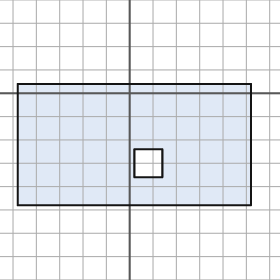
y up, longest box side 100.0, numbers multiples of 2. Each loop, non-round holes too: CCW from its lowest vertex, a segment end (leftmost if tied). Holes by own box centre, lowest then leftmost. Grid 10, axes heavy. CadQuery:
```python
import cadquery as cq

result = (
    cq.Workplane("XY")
    .moveTo(-48.0, -48.0)
    .lineTo(52.0, -48.0)
    .lineTo(52.0, 4.0)
    .lineTo(-48.0, 4.0)
    .close()
    .moveTo(2.0, -36.0)
    .lineTo(14.0, -36.0)
    .lineTo(14.0, -24.0)
    .lineTo(2.0, -24.0)
    .close()
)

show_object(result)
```